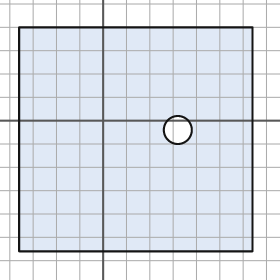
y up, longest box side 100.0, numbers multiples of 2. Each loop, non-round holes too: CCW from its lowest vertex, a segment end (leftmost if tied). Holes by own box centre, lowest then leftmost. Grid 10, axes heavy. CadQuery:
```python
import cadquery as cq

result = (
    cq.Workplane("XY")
    .moveTo(-36.0, -56.0)
    .lineTo(64.0, -56.0)
    .lineTo(64.0, 40.0)
    .lineTo(-36.0, 40.0)
    .close()
    .moveTo(32.0, -4.0)
    .circle(6.0)
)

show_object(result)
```